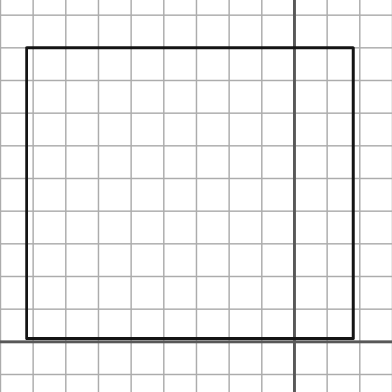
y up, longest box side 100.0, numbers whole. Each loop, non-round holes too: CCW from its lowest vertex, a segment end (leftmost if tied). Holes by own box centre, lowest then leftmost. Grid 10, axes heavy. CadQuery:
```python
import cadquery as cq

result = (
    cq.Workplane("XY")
    .moveTo(-82.0, 1.0)
    .lineTo(18.0, 1.0)
    .lineTo(18.0, 90.0)
    .lineTo(-82.0, 90.0)
    .close()
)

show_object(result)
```